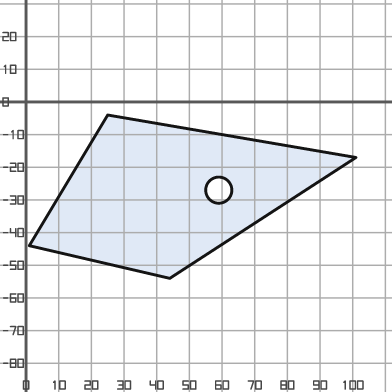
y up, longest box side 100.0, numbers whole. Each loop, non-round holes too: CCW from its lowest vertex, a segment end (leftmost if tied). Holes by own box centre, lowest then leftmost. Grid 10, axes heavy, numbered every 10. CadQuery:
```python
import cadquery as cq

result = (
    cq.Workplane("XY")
    .moveTo(44.0, -54.0)
    .lineTo(101.0, -17.0)
    .lineTo(25.0, -4.0)
    .lineTo(1.0, -44.0)
    .close()
    .moveTo(59.0, -27.0)
    .circle(4.0)
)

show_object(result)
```